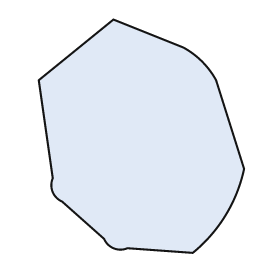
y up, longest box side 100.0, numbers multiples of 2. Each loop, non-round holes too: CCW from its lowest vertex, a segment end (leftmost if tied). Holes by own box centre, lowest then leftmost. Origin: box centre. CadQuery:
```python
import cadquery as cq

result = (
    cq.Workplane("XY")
    .moveTo(22.0, -50.0)
    .threePointArc((36.0, -34.0), (44.0, -14.0))
    .lineTo(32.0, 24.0)
    .threePointArc((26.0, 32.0), (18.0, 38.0))
    .lineTo(-12.0, 50.0)
    .lineTo(-44.0, 24.0)
    .lineTo(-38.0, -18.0)
    .threePointArc((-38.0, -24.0), (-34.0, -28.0))
    .lineTo(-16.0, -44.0)
    .threePointArc((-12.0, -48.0), (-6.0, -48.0))
    .close()
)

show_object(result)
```